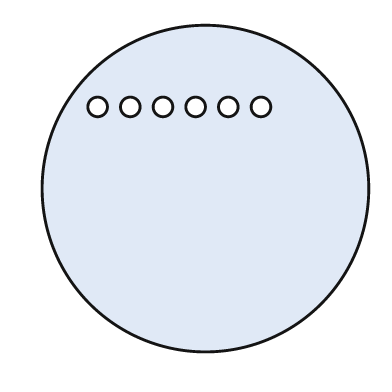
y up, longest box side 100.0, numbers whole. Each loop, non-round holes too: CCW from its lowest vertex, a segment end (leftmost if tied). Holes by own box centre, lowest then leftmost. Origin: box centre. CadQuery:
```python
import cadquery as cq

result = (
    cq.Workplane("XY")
    .moveTo(0.0, 0.0)
    .circle(50.0)
    .moveTo(-33.0, 25.0)
    .circle(3.0)
    .moveTo(-23.0, 25.0)
    .circle(3.0)
    .moveTo(-13.0, 25.0)
    .circle(3.0)
    .moveTo(-3.0, 25.0)
    .circle(3.0)
    .moveTo(7.0, 25.0)
    .circle(3.0)
    .moveTo(17.0, 25.0)
    .circle(3.0)
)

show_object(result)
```